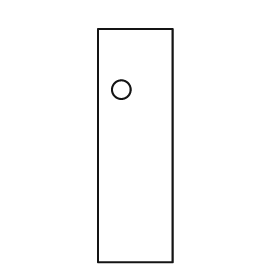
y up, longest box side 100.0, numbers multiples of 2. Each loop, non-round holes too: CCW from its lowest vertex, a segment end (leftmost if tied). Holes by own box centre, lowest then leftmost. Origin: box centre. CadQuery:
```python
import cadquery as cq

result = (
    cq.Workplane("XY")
    .moveTo(-16.0, -50.0)
    .lineTo(16.0, -50.0)
    .lineTo(16.0, 50.0)
    .lineTo(-16.0, 50.0)
    .close()
    .moveTo(-6.0, 24.0)
    .circle(4.0)
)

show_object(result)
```